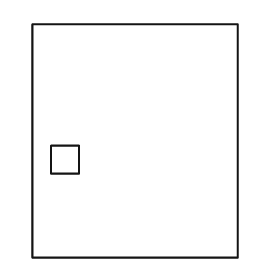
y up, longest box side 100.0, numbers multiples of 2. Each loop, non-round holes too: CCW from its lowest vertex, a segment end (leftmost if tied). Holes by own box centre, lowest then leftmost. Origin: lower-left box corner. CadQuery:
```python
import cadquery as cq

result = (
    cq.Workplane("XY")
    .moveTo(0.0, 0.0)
    .lineTo(88.0, 0.0)
    .lineTo(88.0, 100.0)
    .lineTo(0.0, 100.0)
    .close()
    .moveTo(8.0, 36.0)
    .lineTo(20.0, 36.0)
    .lineTo(20.0, 48.0)
    .lineTo(8.0, 48.0)
    .close()
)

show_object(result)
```